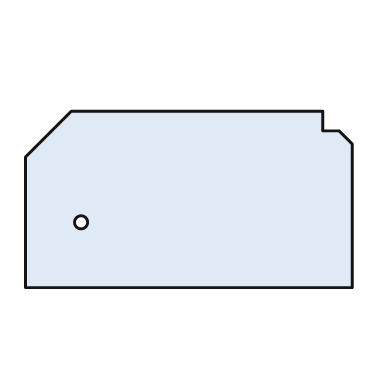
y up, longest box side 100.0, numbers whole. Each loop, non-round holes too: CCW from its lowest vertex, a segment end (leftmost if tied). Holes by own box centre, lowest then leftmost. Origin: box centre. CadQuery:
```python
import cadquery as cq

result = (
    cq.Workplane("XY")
    .moveTo(-50.0, -27.0)
    .lineTo(50.0, -27.0)
    .lineTo(50.0, 17.0)
    .lineTo(46.0, 21.0)
    .lineTo(41.0, 21.0)
    .lineTo(41.0, 27.0)
    .lineTo(-36.0, 27.0)
    .lineTo(-50.0, 13.0)
    .close()
    .moveTo(-33.0, -7.0)
    .circle(2.0)
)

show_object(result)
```